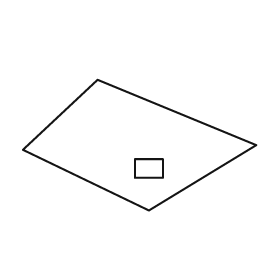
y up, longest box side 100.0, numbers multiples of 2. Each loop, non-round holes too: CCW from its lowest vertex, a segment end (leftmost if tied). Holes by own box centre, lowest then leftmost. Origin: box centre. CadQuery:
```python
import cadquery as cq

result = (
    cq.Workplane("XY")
    .moveTo(4.0, -28.0)
    .lineTo(50.0, 0.0)
    .lineTo(-18.0, 28.0)
    .lineTo(-50.0, -2.0)
    .close()
    .moveTo(-2.0, -14.0)
    .lineTo(10.0, -14.0)
    .lineTo(10.0, -6.0)
    .lineTo(-2.0, -6.0)
    .close()
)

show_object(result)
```